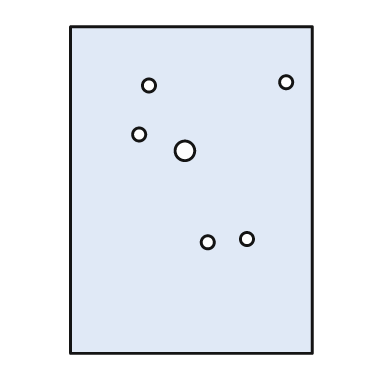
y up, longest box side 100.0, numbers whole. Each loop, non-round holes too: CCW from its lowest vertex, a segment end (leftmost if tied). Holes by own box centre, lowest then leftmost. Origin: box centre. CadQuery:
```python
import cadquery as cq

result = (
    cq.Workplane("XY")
    .moveTo(-37.0, -50.0)
    .lineTo(37.0, -50.0)
    .lineTo(37.0, 50.0)
    .lineTo(-37.0, 50.0)
    .close()
    .moveTo(5.0, -16.0)
    .circle(2.0)
    .moveTo(17.0, -15.0)
    .circle(2.0)
    .moveTo(-2.0, 12.0)
    .circle(3.0)
    .moveTo(-16.0, 17.0)
    .circle(2.0)
    .moveTo(-13.0, 32.0)
    .circle(2.0)
    .moveTo(29.0, 33.0)
    .circle(2.0)
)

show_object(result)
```